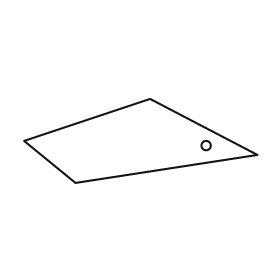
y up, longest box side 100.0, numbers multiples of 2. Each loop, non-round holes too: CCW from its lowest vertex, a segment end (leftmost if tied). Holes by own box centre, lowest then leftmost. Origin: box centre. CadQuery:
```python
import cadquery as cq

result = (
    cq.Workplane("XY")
    .moveTo(-28.0, -18.0)
    .lineTo(50.0, -6.0)
    .lineTo(4.0, 18.0)
    .lineTo(-50.0, 0.0)
    .close()
    .moveTo(28.0, -2.0)
    .circle(2.0)
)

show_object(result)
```